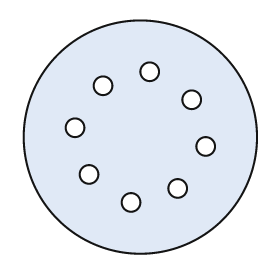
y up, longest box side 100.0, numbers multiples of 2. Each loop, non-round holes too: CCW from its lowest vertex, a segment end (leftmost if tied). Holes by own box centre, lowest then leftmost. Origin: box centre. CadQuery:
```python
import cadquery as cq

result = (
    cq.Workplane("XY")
    .moveTo(0.0, 0.0)
    .circle(50.0)
    .moveTo(-4.0, -28.0)
    .circle(4.0)
    .moveTo(16.0, -22.0)
    .circle(4.0)
    .moveTo(-22.0, -16.0)
    .circle(4.0)
    .moveTo(28.0, -4.0)
    .circle(4.0)
    .moveTo(-28.0, 4.0)
    .circle(4.0)
    .moveTo(22.0, 16.0)
    .circle(4.0)
    .moveTo(-16.0, 22.0)
    .circle(4.0)
    .moveTo(4.0, 28.0)
    .circle(4.0)
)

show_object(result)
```